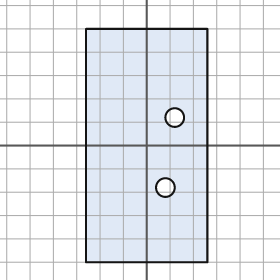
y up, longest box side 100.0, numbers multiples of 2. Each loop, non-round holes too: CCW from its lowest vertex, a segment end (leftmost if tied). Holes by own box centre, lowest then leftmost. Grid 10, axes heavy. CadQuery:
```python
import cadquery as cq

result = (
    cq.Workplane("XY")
    .moveTo(-26.0, -50.0)
    .lineTo(26.0, -50.0)
    .lineTo(26.0, 50.0)
    .lineTo(-26.0, 50.0)
    .close()
    .moveTo(8.0, -18.0)
    .circle(4.0)
    .moveTo(12.0, 12.0)
    .circle(4.0)
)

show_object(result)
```